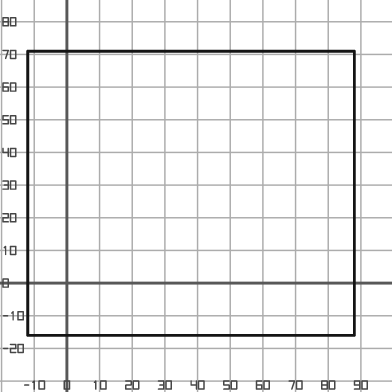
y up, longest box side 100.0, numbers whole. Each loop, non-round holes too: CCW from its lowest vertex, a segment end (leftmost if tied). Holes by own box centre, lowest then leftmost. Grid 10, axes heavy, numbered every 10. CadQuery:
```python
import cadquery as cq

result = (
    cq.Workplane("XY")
    .moveTo(-12.0, -16.0)
    .lineTo(88.0, -16.0)
    .lineTo(88.0, 71.0)
    .lineTo(-12.0, 71.0)
    .close()
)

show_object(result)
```